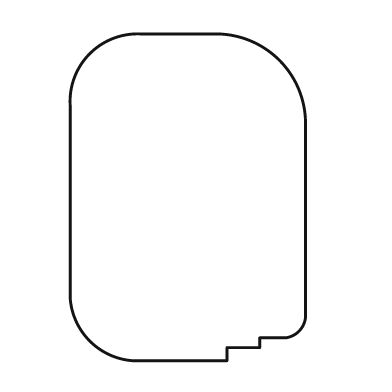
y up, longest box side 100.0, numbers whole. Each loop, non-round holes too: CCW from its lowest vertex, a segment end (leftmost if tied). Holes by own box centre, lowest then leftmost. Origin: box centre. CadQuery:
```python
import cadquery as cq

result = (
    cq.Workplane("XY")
    .moveTo(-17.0, -50.0)
    .lineTo(12.0, -50.0)
    .lineTo(12.0, -46.0)
    .lineTo(22.0, -46.0)
    .lineTo(22.0, -43.0)
    .lineTo(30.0, -43.0)
    .threePointArc((34.0, -41.0), (36.0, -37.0))
    .lineTo(36.0, 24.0)
    .threePointArc((28.0, 42.0), (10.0, 50.0))
    .lineTo(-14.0, 50.0)
    .threePointArc((-30.0, 44.0), (-36.0, 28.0))
    .lineTo(-36.0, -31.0)
    .threePointArc((-30.0, -44.0), (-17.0, -50.0))
    .close()
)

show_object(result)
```